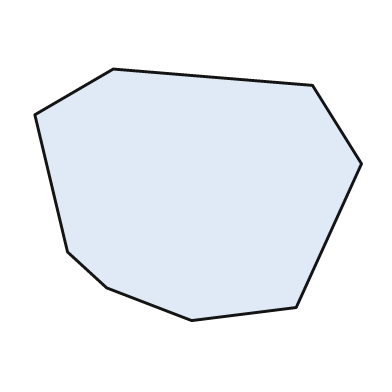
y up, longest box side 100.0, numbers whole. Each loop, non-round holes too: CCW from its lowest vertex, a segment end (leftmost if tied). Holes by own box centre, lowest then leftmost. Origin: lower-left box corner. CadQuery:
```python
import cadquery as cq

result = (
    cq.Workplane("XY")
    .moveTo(48.0, 0.0)
    .lineTo(80.0, 4.0)
    .lineTo(100.0, 48.0)
    .lineTo(85.0, 72.0)
    .lineTo(24.0, 77.0)
    .lineTo(0.0, 63.0)
    .lineTo(10.0, 21.0)
    .lineTo(22.0, 10.0)
    .close()
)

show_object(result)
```